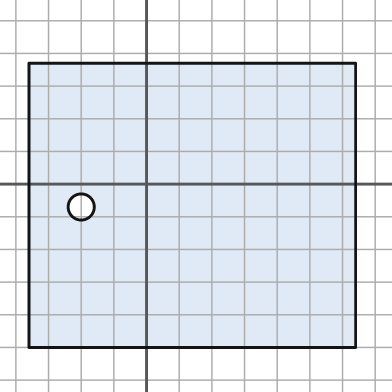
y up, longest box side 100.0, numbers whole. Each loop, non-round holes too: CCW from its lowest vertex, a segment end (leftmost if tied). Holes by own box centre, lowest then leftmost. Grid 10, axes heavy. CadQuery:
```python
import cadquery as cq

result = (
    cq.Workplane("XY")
    .moveTo(-36.0, -50.0)
    .lineTo(64.0, -50.0)
    .lineTo(64.0, 37.0)
    .lineTo(-36.0, 37.0)
    .close()
    .moveTo(-20.0, -7.0)
    .circle(4.0)
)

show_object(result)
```